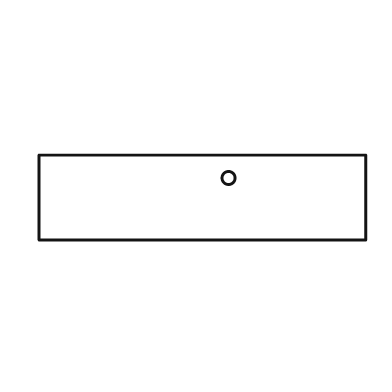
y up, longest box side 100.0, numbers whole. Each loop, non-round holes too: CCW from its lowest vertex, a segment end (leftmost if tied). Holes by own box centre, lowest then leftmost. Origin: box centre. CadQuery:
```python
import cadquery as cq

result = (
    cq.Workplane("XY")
    .moveTo(-50.0, -13.0)
    .lineTo(50.0, -13.0)
    .lineTo(50.0, 13.0)
    .lineTo(-50.0, 13.0)
    .close()
    .moveTo(8.0, 6.0)
    .circle(2.0)
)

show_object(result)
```